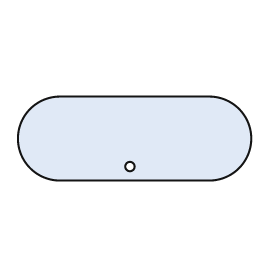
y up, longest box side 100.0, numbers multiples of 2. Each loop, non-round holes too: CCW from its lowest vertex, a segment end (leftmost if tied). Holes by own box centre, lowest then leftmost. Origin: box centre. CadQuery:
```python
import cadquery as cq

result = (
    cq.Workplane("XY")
    .moveTo(-32.0, -18.0)
    .lineTo(32.0, -18.0)
    .threePointArc((50.0, 0.0), (32.0, 18.0))
    .lineTo(-32.0, 18.0)
    .threePointArc((-50.0, 0.0), (-32.0, -18.0))
    .close()
    .moveTo(-2.0, -12.0)
    .circle(2.0)
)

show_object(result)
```